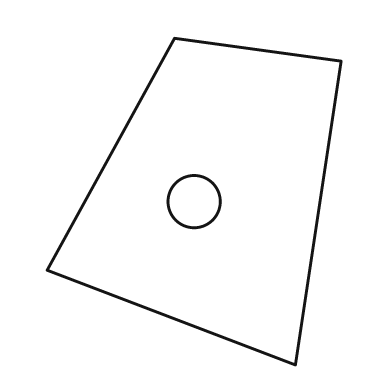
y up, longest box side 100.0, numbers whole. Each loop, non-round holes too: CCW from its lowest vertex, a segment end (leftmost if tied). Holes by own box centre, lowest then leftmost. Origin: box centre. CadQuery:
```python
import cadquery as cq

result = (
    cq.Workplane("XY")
    .moveTo(31.0, -50.0)
    .lineTo(45.0, 43.0)
    .lineTo(-6.0, 50.0)
    .lineTo(-45.0, -21.0)
    .close()
    .moveTo(0.0, 0.0)
    .circle(8.0)
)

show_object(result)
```